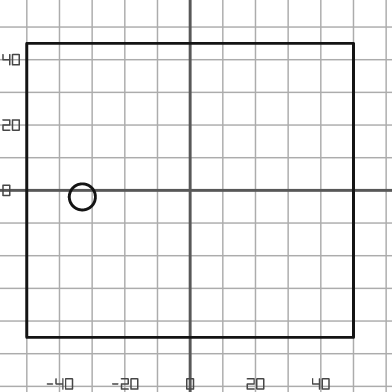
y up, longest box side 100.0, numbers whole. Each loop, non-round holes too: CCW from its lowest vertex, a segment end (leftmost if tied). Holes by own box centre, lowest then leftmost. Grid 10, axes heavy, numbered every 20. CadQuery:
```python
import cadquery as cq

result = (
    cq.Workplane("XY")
    .moveTo(-50.0, -45.0)
    .lineTo(50.0, -45.0)
    .lineTo(50.0, 45.0)
    .lineTo(-50.0, 45.0)
    .close()
    .moveTo(-33.0, -2.0)
    .circle(4.0)
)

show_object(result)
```